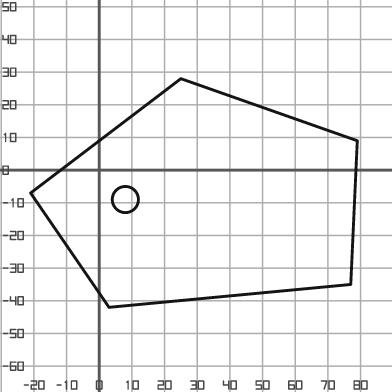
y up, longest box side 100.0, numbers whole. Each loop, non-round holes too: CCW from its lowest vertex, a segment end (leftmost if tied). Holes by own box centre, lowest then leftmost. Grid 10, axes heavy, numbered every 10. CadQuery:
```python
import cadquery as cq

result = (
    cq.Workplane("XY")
    .moveTo(3.0, -42.0)
    .lineTo(77.0, -35.0)
    .lineTo(79.0, 9.0)
    .lineTo(25.0, 28.0)
    .lineTo(-21.0, -7.0)
    .close()
    .moveTo(8.0, -9.0)
    .circle(4.0)
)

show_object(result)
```